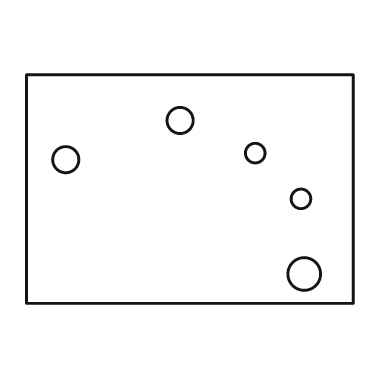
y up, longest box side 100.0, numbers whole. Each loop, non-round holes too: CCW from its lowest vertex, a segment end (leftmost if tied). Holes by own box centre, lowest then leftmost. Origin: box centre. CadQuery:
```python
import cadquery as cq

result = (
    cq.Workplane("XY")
    .moveTo(-50.0, -35.0)
    .lineTo(50.0, -35.0)
    .lineTo(50.0, 35.0)
    .lineTo(-50.0, 35.0)
    .close()
    .moveTo(35.0, -26.0)
    .circle(5.0)
    .moveTo(34.0, -3.0)
    .circle(3.0)
    .moveTo(-38.0, 9.0)
    .circle(4.0)
    .moveTo(20.0, 11.0)
    .circle(3.0)
    .moveTo(-3.0, 21.0)
    .circle(4.0)
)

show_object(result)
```